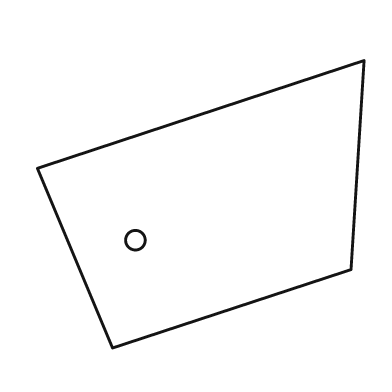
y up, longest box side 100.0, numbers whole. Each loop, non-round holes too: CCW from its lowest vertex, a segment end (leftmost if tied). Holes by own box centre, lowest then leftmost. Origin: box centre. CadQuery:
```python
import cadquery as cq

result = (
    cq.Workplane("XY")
    .moveTo(-27.0, -44.0)
    .lineTo(46.0, -20.0)
    .lineTo(50.0, 44.0)
    .lineTo(-50.0, 11.0)
    .close()
    .moveTo(-20.0, -11.0)
    .circle(3.0)
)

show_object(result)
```